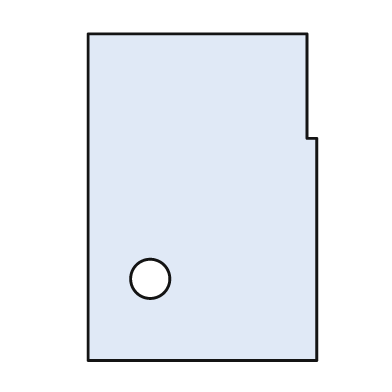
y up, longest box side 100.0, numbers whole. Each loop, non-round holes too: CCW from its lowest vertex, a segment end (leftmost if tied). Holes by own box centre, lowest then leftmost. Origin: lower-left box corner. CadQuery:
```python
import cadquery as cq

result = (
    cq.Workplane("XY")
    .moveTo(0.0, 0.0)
    .lineTo(70.0, 0.0)
    .lineTo(70.0, 68.0)
    .lineTo(67.0, 68.0)
    .lineTo(67.0, 100.0)
    .lineTo(0.0, 100.0)
    .close()
    .moveTo(19.0, 25.0)
    .circle(6.0)
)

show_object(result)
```